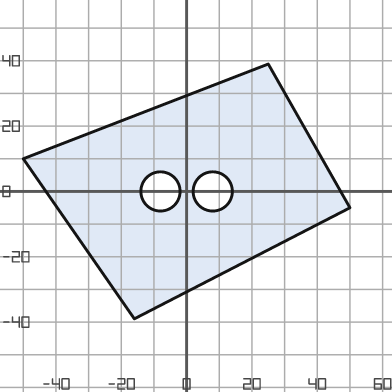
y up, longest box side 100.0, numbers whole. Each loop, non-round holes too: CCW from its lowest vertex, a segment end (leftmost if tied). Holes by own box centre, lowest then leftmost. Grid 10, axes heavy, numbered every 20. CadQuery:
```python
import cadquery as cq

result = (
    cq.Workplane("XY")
    .moveTo(-16.0, -39.0)
    .lineTo(50.0, -5.0)
    .lineTo(25.0, 39.0)
    .lineTo(-50.0, 10.0)
    .close()
    .moveTo(-8.0, 0.0)
    .circle(6.0)
    .moveTo(8.0, 0.0)
    .circle(6.0)
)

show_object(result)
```